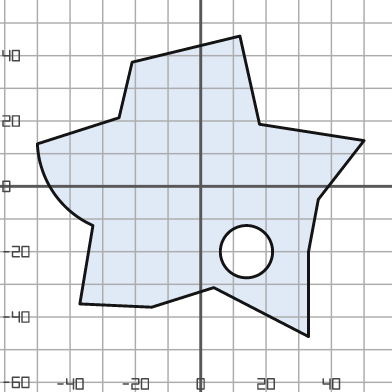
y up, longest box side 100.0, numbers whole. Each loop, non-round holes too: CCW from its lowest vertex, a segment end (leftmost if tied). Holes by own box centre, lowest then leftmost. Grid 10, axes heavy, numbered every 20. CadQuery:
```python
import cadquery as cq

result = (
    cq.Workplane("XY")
    .moveTo(33.0, -46.0)
    .lineTo(33.0, -20.0)
    .lineTo(36.0, -4.0)
    .lineTo(50.0, 14.0)
    .lineTo(18.0, 19.0)
    .lineTo(12.0, 46.0)
    .lineTo(-21.0, 38.0)
    .lineTo(-25.0, 21.0)
    .lineTo(-50.0, 13.0)
    .threePointArc((-45.0, -2.0), (-33.0, -12.0))
    .lineTo(-37.0, -36.0)
    .lineTo(-15.0, -37.0)
    .lineTo(4.0, -31.0)
    .close()
    .moveTo(14.0, -20.0)
    .circle(8.0)
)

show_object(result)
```